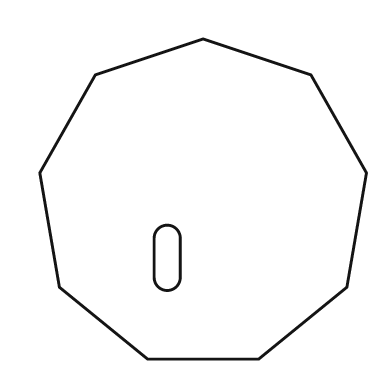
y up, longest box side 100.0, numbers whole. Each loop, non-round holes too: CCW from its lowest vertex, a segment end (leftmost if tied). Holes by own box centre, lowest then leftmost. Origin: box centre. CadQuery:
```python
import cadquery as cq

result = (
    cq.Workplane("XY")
    .moveTo(-17.0, -49.0)
    .lineTo(17.0, -49.0)
    .lineTo(44.0, -27.0)
    .lineTo(50.0, 8.0)
    .lineTo(33.0, 38.0)
    .lineTo(0.0, 49.0)
    .lineTo(-33.0, 38.0)
    .lineTo(-50.0, 8.0)
    .lineTo(-44.0, -27.0)
    .close()
    .moveTo(-15.0, -24.0)
    .threePointArc((-11.0, -28.0), (-7.0, -24.0))
    .lineTo(-7.0, -12.0)
    .threePointArc((-11.0, -8.0), (-15.0, -12.0))
    .close()
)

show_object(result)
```